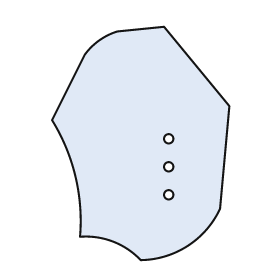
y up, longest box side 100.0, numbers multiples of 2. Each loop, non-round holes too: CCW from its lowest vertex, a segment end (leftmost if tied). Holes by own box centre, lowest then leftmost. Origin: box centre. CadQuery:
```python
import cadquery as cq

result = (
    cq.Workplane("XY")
    .moveTo(0.0, -50.0)
    .threePointArc((20.0, -44.0), (34.0, -28.0))
    .lineTo(38.0, 16.0)
    .lineTo(10.0, 50.0)
    .lineTo(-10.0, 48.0)
    .threePointArc((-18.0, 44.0), (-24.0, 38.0))
    .lineTo(-38.0, 10.0)
    .threePointArc((-28.0, -14.0), (-26.0, -40.0))
    .threePointArc((-12.0, -42.0), (0.0, -50.0))
    .close()
    .moveTo(12.0, -22.0)
    .circle(2.0)
    .moveTo(12.0, -10.0)
    .circle(2.0)
    .moveTo(12.0, 2.0)
    .circle(2.0)
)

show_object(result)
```